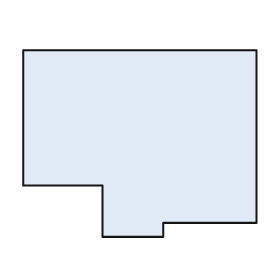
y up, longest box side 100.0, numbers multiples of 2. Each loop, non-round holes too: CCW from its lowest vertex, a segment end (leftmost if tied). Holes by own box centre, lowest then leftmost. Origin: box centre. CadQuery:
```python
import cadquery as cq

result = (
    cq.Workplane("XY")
    .moveTo(-16.0, -40.0)
    .lineTo(10.0, -40.0)
    .lineTo(10.0, -34.0)
    .lineTo(50.0, -34.0)
    .lineTo(50.0, 40.0)
    .lineTo(-50.0, 40.0)
    .lineTo(-50.0, -18.0)
    .lineTo(-16.0, -18.0)
    .close()
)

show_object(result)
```